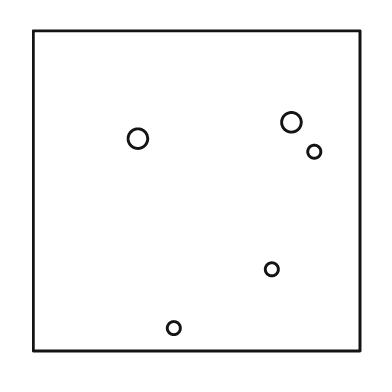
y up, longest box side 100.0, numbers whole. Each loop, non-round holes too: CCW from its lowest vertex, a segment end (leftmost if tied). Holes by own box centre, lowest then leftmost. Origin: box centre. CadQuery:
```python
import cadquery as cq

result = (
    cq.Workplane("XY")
    .moveTo(-50.0, -49.0)
    .lineTo(50.0, -49.0)
    .lineTo(50.0, 49.0)
    .lineTo(-50.0, 49.0)
    .close()
    .moveTo(-7.0, -42.0)
    .circle(2.0)
    .moveTo(23.0, -24.0)
    .circle(2.0)
    .moveTo(36.0, 12.0)
    .circle(2.0)
    .moveTo(-18.0, 16.0)
    .circle(3.0)
    .moveTo(29.0, 21.0)
    .circle(3.0)
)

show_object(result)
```